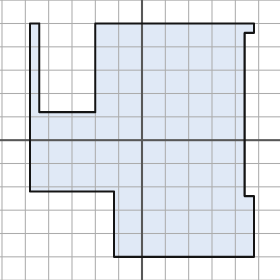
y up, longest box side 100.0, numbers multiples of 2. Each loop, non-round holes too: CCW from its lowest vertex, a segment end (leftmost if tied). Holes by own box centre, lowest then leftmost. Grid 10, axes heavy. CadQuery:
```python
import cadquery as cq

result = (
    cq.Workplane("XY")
    .moveTo(-12.0, -50.0)
    .lineTo(48.0, -50.0)
    .lineTo(48.0, -24.0)
    .lineTo(44.0, -24.0)
    .lineTo(44.0, 46.0)
    .lineTo(48.0, 46.0)
    .lineTo(48.0, 50.0)
    .lineTo(-20.0, 50.0)
    .lineTo(-20.0, 12.0)
    .lineTo(-44.0, 12.0)
    .lineTo(-44.0, 50.0)
    .lineTo(-48.0, 50.0)
    .lineTo(-48.0, -22.0)
    .lineTo(-12.0, -22.0)
    .close()
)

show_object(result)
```